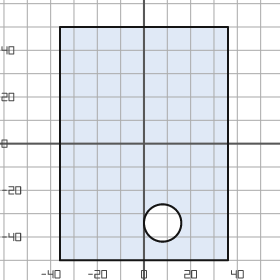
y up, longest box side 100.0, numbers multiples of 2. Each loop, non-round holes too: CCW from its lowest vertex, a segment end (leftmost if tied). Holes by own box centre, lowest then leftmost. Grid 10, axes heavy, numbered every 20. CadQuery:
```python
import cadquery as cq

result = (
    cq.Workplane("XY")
    .moveTo(-36.0, -50.0)
    .lineTo(36.0, -50.0)
    .lineTo(36.0, 50.0)
    .lineTo(-36.0, 50.0)
    .close()
    .moveTo(8.0, -34.0)
    .circle(8.0)
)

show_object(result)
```